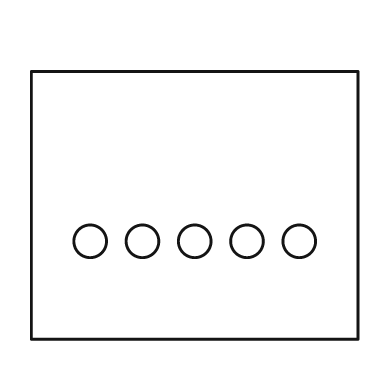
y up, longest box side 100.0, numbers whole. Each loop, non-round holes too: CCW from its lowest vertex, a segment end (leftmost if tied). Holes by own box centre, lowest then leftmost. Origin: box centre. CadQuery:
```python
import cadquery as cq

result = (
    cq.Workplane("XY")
    .moveTo(-50.0, -41.0)
    .lineTo(50.0, -41.0)
    .lineTo(50.0, 41.0)
    .lineTo(-50.0, 41.0)
    .close()
    .moveTo(-32.0, -11.0)
    .circle(5.0)
    .moveTo(-16.0, -11.0)
    .circle(5.0)
    .moveTo(0.0, -11.0)
    .circle(5.0)
    .moveTo(16.0, -11.0)
    .circle(5.0)
    .moveTo(32.0, -11.0)
    .circle(5.0)
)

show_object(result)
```